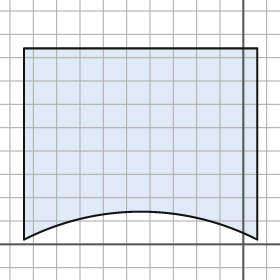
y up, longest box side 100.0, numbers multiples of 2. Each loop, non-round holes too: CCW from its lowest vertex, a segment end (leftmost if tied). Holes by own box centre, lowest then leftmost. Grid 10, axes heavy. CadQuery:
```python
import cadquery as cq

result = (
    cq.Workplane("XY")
    .moveTo(-94.0, 2.0)
    .threePointArc((-44.0, 14.0), (6.0, 2.0))
    .lineTo(6.0, 84.0)
    .lineTo(-94.0, 84.0)
    .close()
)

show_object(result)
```